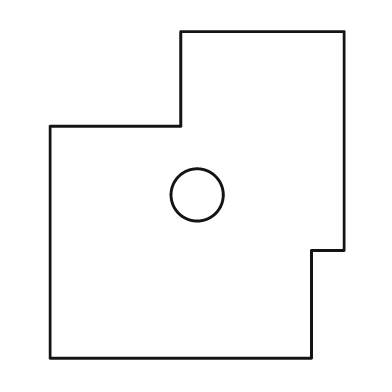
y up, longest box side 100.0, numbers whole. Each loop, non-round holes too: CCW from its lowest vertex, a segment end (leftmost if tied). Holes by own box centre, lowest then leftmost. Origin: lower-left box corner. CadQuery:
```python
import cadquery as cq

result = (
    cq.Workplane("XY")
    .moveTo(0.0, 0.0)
    .lineTo(80.0, 0.0)
    .lineTo(80.0, 33.0)
    .lineTo(90.0, 33.0)
    .lineTo(90.0, 100.0)
    .lineTo(40.0, 100.0)
    .lineTo(40.0, 71.0)
    .lineTo(0.0, 71.0)
    .close()
    .moveTo(45.0, 50.0)
    .circle(8.0)
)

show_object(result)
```